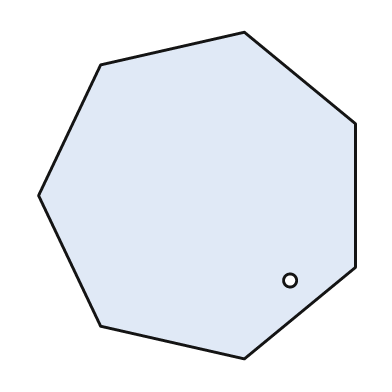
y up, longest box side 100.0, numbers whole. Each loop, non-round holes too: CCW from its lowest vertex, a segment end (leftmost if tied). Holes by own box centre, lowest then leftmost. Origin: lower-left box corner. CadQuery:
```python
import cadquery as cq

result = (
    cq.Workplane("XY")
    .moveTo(63.0, 0.0)
    .lineTo(97.0, 28.0)
    .lineTo(97.0, 72.0)
    .lineTo(63.0, 100.0)
    .lineTo(19.0, 90.0)
    .lineTo(0.0, 50.0)
    .lineTo(19.0, 10.0)
    .close()
    .moveTo(77.0, 24.0)
    .circle(2.0)
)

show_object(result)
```